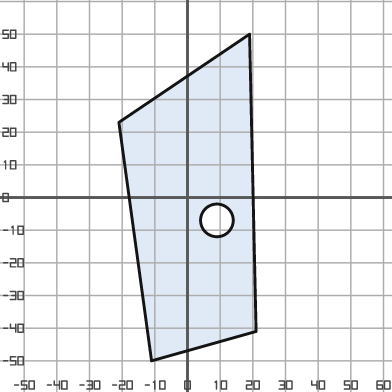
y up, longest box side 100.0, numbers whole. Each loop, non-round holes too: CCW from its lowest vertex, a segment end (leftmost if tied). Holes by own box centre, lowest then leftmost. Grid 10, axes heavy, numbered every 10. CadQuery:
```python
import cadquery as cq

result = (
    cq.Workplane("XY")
    .moveTo(-11.0, -50.0)
    .lineTo(21.0, -41.0)
    .lineTo(19.0, 50.0)
    .lineTo(-21.0, 23.0)
    .close()
    .moveTo(9.0, -7.0)
    .circle(5.0)
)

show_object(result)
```